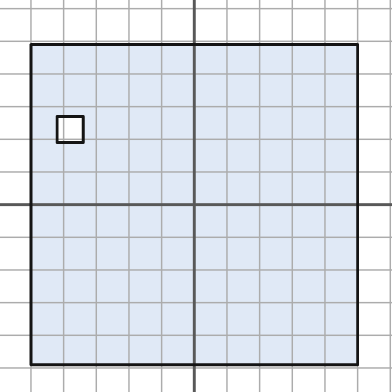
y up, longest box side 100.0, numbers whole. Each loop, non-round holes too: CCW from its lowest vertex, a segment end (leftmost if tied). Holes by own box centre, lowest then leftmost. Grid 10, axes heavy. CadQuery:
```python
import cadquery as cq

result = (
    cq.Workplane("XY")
    .moveTo(-50.0, -49.0)
    .lineTo(50.0, -49.0)
    .lineTo(50.0, 49.0)
    .lineTo(-50.0, 49.0)
    .close()
    .moveTo(-42.0, 19.0)
    .lineTo(-34.0, 19.0)
    .lineTo(-34.0, 27.0)
    .lineTo(-42.0, 27.0)
    .close()
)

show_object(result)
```